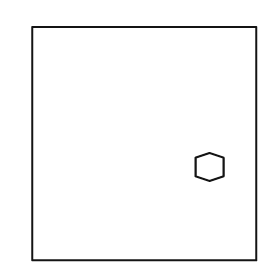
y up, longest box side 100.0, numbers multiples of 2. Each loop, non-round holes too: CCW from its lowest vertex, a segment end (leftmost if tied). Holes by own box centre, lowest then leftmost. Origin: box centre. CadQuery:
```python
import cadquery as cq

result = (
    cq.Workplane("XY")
    .moveTo(-48.0, -50.0)
    .lineTo(48.0, -50.0)
    .lineTo(48.0, 50.0)
    .lineTo(-48.0, 50.0)
    .close()
    .moveTo(28.0, -16.0)
    .lineTo(34.0, -14.0)
    .lineTo(34.0, -6.0)
    .lineTo(28.0, -4.0)
    .lineTo(22.0, -6.0)
    .lineTo(22.0, -14.0)
    .close()
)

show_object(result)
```